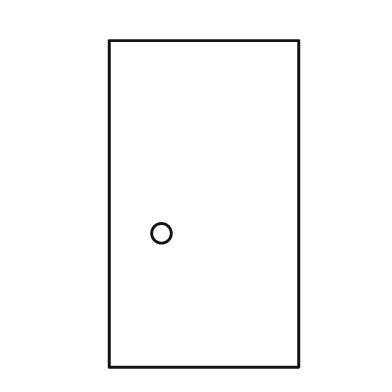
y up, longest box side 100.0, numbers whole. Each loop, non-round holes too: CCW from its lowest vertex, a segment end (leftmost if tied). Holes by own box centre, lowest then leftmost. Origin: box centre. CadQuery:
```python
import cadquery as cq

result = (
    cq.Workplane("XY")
    .moveTo(-29.0, -50.0)
    .lineTo(29.0, -50.0)
    .lineTo(29.0, 50.0)
    .lineTo(-29.0, 50.0)
    .close()
    .moveTo(-13.0, -9.0)
    .circle(3.0)
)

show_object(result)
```